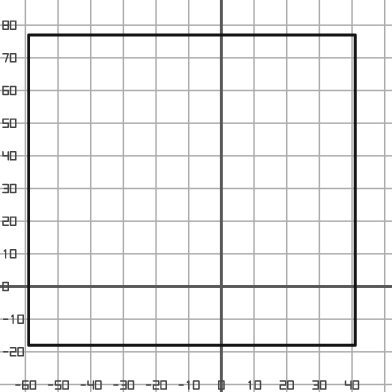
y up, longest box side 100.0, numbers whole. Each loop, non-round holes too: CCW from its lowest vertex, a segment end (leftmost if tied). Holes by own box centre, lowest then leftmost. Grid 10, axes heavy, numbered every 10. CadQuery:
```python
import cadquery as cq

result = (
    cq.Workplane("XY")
    .moveTo(-59.0, -18.0)
    .lineTo(41.0, -18.0)
    .lineTo(41.0, 77.0)
    .lineTo(-59.0, 77.0)
    .close()
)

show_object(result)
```